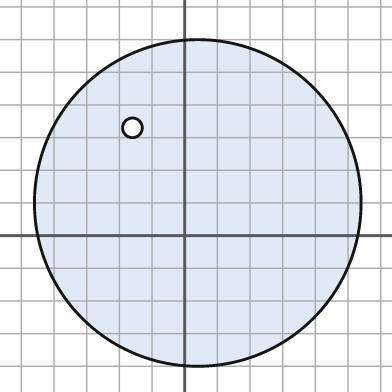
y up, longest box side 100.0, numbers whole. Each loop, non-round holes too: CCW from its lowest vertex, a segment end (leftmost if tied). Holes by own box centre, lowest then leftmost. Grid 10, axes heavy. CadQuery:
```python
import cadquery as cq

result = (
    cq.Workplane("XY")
    .moveTo(4.0, 10.0)
    .circle(50.0)
    .moveTo(-16.0, 33.0)
    .circle(3.0)
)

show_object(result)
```